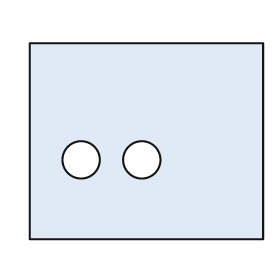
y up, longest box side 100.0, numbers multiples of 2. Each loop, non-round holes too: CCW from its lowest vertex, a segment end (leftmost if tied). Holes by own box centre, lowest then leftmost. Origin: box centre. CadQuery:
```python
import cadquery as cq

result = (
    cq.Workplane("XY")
    .moveTo(-50.0, -42.0)
    .lineTo(50.0, -42.0)
    .lineTo(50.0, 42.0)
    .lineTo(-50.0, 42.0)
    .close()
    .moveTo(-28.0, -8.0)
    .circle(8.0)
    .moveTo(-2.0, -8.0)
    .circle(8.0)
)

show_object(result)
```